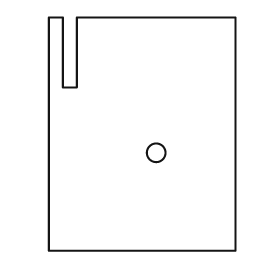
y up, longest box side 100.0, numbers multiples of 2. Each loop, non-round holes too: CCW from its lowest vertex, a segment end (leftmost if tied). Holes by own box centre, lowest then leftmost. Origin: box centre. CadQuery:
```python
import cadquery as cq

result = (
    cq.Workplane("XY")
    .moveTo(-40.0, -50.0)
    .lineTo(40.0, -50.0)
    .lineTo(40.0, 50.0)
    .lineTo(-28.0, 50.0)
    .lineTo(-28.0, 20.0)
    .lineTo(-34.0, 20.0)
    .lineTo(-34.0, 50.0)
    .lineTo(-40.0, 50.0)
    .close()
    .moveTo(6.0, -8.0)
    .circle(4.0)
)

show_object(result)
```